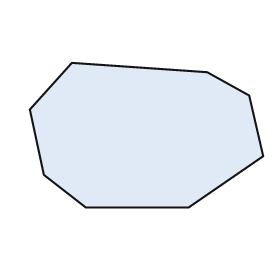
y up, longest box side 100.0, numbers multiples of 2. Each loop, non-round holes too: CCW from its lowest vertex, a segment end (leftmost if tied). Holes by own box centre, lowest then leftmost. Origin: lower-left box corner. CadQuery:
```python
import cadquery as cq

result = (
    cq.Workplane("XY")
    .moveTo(24.0, 0.0)
    .lineTo(68.0, 0.0)
    .lineTo(100.0, 22.0)
    .lineTo(94.0, 48.0)
    .lineTo(76.0, 58.0)
    .lineTo(18.0, 62.0)
    .lineTo(0.0, 42.0)
    .lineTo(6.0, 14.0)
    .close()
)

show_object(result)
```